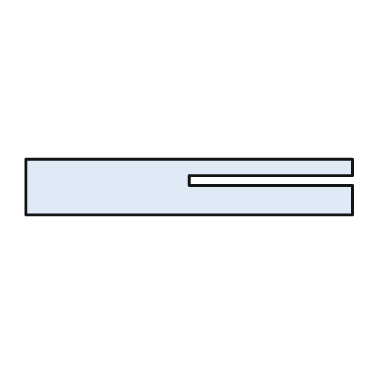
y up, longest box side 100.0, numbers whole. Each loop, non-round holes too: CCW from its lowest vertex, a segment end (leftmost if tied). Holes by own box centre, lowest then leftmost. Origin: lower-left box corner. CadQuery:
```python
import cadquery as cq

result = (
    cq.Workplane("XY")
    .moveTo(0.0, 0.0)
    .lineTo(100.0, 0.0)
    .lineTo(100.0, 9.0)
    .lineTo(50.0, 9.0)
    .lineTo(50.0, 12.0)
    .lineTo(100.0, 12.0)
    .lineTo(100.0, 17.0)
    .lineTo(0.0, 17.0)
    .close()
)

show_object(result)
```